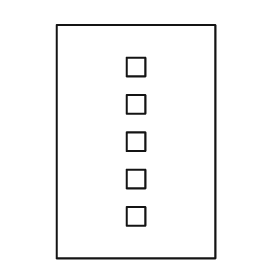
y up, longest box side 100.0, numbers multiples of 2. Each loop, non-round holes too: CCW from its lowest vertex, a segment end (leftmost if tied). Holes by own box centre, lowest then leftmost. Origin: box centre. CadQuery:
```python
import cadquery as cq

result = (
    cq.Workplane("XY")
    .moveTo(-34.0, -50.0)
    .lineTo(34.0, -50.0)
    .lineTo(34.0, 50.0)
    .lineTo(-34.0, 50.0)
    .close()
    .moveTo(-4.0, -36.0)
    .lineTo(4.0, -36.0)
    .lineTo(4.0, -28.0)
    .lineTo(-4.0, -28.0)
    .close()
    .moveTo(-4.0, -20.0)
    .lineTo(4.0, -20.0)
    .lineTo(4.0, -12.0)
    .lineTo(-4.0, -12.0)
    .close()
    .moveTo(-4.0, -4.0)
    .lineTo(4.0, -4.0)
    .lineTo(4.0, 4.0)
    .lineTo(-4.0, 4.0)
    .close()
    .moveTo(-4.0, 12.0)
    .lineTo(4.0, 12.0)
    .lineTo(4.0, 20.0)
    .lineTo(-4.0, 20.0)
    .close()
    .moveTo(-4.0, 28.0)
    .lineTo(4.0, 28.0)
    .lineTo(4.0, 36.0)
    .lineTo(-4.0, 36.0)
    .close()
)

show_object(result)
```